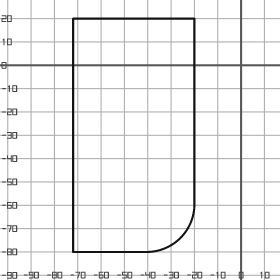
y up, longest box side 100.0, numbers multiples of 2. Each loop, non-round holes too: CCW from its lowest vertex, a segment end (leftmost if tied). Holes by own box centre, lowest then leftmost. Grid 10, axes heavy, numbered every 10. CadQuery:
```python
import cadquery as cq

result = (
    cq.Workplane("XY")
    .moveTo(-72.0, -80.0)
    .lineTo(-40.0, -80.0)
    .threePointArc((-26.0, -74.0), (-20.0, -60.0))
    .lineTo(-20.0, 20.0)
    .lineTo(-72.0, 20.0)
    .close()
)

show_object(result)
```